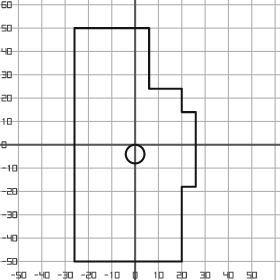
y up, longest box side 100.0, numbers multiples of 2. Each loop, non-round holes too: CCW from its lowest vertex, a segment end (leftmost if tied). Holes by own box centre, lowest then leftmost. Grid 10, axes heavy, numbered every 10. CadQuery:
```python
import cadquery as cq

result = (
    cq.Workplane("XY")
    .moveTo(-26.0, -50.0)
    .lineTo(20.0, -50.0)
    .lineTo(20.0, -18.0)
    .lineTo(26.0, -18.0)
    .lineTo(26.0, 14.0)
    .lineTo(20.0, 14.0)
    .lineTo(20.0, 24.0)
    .lineTo(6.0, 24.0)
    .lineTo(6.0, 50.0)
    .lineTo(-26.0, 50.0)
    .close()
    .moveTo(0.0, -4.0)
    .circle(4.0)
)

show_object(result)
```